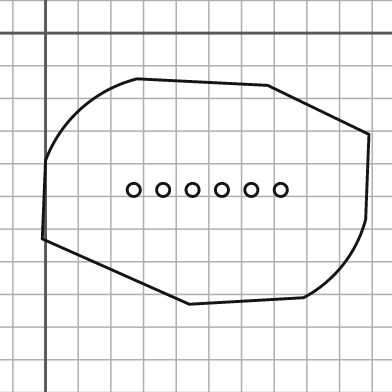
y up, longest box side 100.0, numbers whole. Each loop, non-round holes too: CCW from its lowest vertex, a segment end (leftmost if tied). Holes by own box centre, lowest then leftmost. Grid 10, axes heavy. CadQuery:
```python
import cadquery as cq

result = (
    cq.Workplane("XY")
    .moveTo(44.0, -83.0)
    .lineTo(79.0, -81.0)
    .threePointArc((91.0, -71.0), (98.0, -57.0))
    .lineTo(99.0, -31.0)
    .lineTo(68.0, -16.0)
    .lineTo(28.0, -14.0)
    .threePointArc((11.0, -23.0), (0.0, -39.0))
    .lineTo(-1.0, -63.0)
    .close()
    .moveTo(27.0, -48.0)
    .circle(2.0)
    .moveTo(36.0, -48.0)
    .circle(2.0)
    .moveTo(45.0, -48.0)
    .circle(2.0)
    .moveTo(54.0, -48.0)
    .circle(2.0)
    .moveTo(63.0, -48.0)
    .circle(2.0)
    .moveTo(72.0, -48.0)
    .circle(2.0)
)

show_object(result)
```